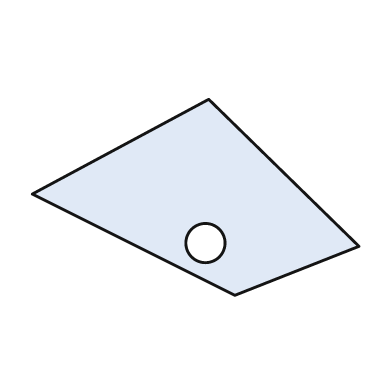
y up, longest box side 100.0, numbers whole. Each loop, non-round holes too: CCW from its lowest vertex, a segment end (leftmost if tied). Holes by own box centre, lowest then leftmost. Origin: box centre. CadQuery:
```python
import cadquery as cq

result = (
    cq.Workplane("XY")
    .moveTo(12.0, -30.0)
    .lineTo(50.0, -15.0)
    .lineTo(4.0, 30.0)
    .lineTo(-50.0, 1.0)
    .close()
    .moveTo(3.0, -14.0)
    .circle(6.0)
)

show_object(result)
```